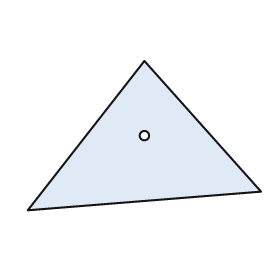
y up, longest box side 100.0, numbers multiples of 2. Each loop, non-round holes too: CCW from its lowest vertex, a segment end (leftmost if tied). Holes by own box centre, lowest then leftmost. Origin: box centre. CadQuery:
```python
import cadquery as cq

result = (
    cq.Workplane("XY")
    .moveTo(-50.0, -32.0)
    .lineTo(50.0, -24.0)
    .lineTo(0.0, 32.0)
    .close()
    .moveTo(0.0, 0.0)
    .circle(2.0)
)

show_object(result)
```